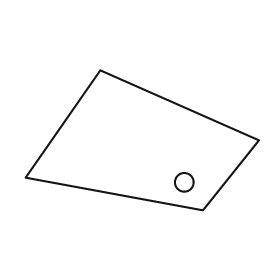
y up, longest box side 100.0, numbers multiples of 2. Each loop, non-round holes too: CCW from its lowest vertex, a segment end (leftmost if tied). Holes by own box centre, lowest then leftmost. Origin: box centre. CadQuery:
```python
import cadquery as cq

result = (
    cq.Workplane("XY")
    .moveTo(26.0, -30.0)
    .lineTo(50.0, 0.0)
    .lineTo(-18.0, 30.0)
    .lineTo(-50.0, -16.0)
    .close()
    .moveTo(18.0, -18.0)
    .circle(4.0)
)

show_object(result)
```